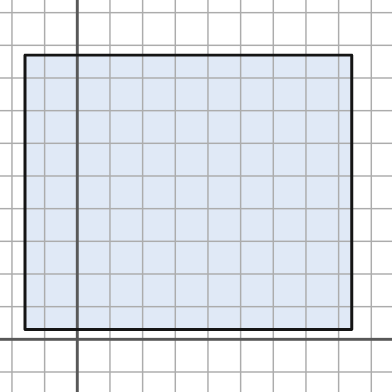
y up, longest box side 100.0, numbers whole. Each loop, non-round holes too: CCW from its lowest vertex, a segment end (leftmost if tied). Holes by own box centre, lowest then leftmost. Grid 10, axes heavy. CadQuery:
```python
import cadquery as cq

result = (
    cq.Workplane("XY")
    .moveTo(-16.0, 3.0)
    .lineTo(84.0, 3.0)
    .lineTo(84.0, 87.0)
    .lineTo(-16.0, 87.0)
    .close()
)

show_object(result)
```